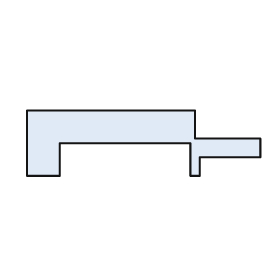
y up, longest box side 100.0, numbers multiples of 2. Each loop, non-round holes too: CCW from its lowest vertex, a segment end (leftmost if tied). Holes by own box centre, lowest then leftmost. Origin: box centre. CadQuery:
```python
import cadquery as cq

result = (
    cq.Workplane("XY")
    .moveTo(-50.0, -14.0)
    .lineTo(-36.0, -14.0)
    .lineTo(-36.0, 0.0)
    .lineTo(20.0, 0.0)
    .lineTo(20.0, -14.0)
    .lineTo(24.0, -14.0)
    .lineTo(24.0, -6.0)
    .lineTo(50.0, -6.0)
    .lineTo(50.0, 2.0)
    .lineTo(22.0, 2.0)
    .lineTo(22.0, 14.0)
    .lineTo(-50.0, 14.0)
    .close()
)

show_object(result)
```